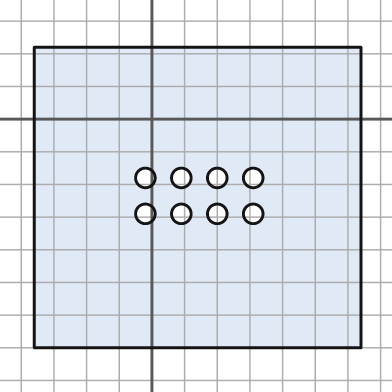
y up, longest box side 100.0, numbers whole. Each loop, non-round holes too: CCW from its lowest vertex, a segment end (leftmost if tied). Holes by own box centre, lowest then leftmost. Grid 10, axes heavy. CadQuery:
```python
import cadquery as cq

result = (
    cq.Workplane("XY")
    .moveTo(-36.0, -70.0)
    .lineTo(64.0, -70.0)
    .lineTo(64.0, 22.0)
    .lineTo(-36.0, 22.0)
    .close()
    .moveTo(-2.0, -29.0)
    .circle(3.0)
    .moveTo(9.0, -29.0)
    .circle(3.0)
    .moveTo(20.0, -29.0)
    .circle(3.0)
    .moveTo(31.0, -29.0)
    .circle(3.0)
    .moveTo(-2.0, -18.0)
    .circle(3.0)
    .moveTo(9.0, -18.0)
    .circle(3.0)
    .moveTo(20.0, -18.0)
    .circle(3.0)
    .moveTo(31.0, -18.0)
    .circle(3.0)
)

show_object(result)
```